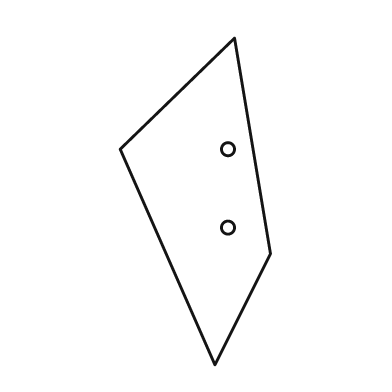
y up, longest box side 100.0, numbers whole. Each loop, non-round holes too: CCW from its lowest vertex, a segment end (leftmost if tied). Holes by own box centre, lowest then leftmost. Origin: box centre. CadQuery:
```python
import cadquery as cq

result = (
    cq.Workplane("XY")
    .moveTo(6.0, -50.0)
    .lineTo(23.0, -16.0)
    .lineTo(12.0, 50.0)
    .lineTo(-23.0, 16.0)
    .close()
    .moveTo(10.0, -8.0)
    .circle(2.0)
    .moveTo(10.0, 16.0)
    .circle(2.0)
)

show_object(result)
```